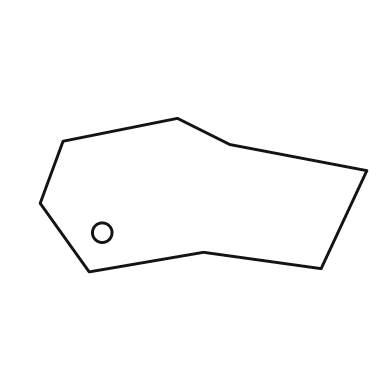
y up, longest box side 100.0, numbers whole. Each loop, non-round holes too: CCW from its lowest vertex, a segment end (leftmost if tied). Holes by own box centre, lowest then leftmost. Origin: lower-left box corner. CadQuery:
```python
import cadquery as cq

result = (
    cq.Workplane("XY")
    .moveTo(15.0, 0.0)
    .lineTo(50.0, 6.0)
    .lineTo(86.0, 1.0)
    .lineTo(100.0, 31.0)
    .lineTo(58.0, 39.0)
    .lineTo(42.0, 47.0)
    .lineTo(7.0, 40.0)
    .lineTo(0.0, 21.0)
    .close()
    .moveTo(19.0, 12.0)
    .circle(3.0)
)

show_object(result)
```